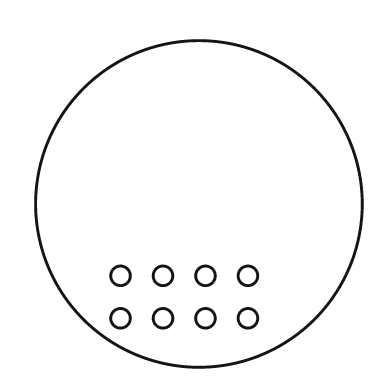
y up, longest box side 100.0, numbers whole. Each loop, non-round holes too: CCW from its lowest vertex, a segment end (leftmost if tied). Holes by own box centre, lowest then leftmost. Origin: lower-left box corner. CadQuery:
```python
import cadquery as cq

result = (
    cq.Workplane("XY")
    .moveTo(50.0, 50.0)
    .circle(50.0)
    .moveTo(26.0, 15.0)
    .circle(3.0)
    .moveTo(39.0, 15.0)
    .circle(3.0)
    .moveTo(52.0, 15.0)
    .circle(3.0)
    .moveTo(65.0, 15.0)
    .circle(3.0)
    .moveTo(26.0, 28.0)
    .circle(3.0)
    .moveTo(39.0, 28.0)
    .circle(3.0)
    .moveTo(52.0, 28.0)
    .circle(3.0)
    .moveTo(65.0, 28.0)
    .circle(3.0)
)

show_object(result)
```